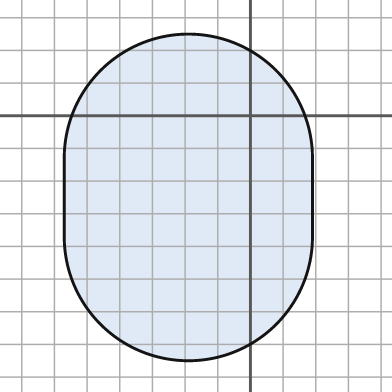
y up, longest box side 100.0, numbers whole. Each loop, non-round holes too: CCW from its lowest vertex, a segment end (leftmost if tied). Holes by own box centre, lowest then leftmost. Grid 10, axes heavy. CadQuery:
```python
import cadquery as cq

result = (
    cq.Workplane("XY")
    .moveTo(-57.0, -37.0)
    .threePointArc((-19.0, -75.0), (19.0, -37.0))
    .lineTo(19.0, -13.0)
    .threePointArc((-19.0, 25.0), (-57.0, -13.0))
    .close()
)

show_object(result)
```